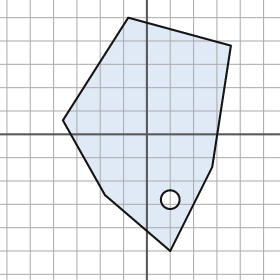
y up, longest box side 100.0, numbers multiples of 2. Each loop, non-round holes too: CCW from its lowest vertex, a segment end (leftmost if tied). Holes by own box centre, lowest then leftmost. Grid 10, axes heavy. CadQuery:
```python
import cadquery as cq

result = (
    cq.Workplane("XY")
    .moveTo(10.0, -50.0)
    .lineTo(28.0, -14.0)
    .lineTo(36.0, 38.0)
    .lineTo(-8.0, 50.0)
    .lineTo(-36.0, 6.0)
    .lineTo(-18.0, -26.0)
    .close()
    .moveTo(10.0, -28.0)
    .circle(4.0)
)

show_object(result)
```